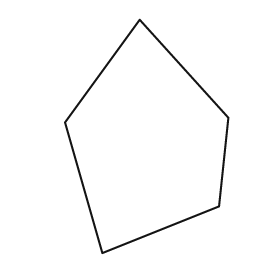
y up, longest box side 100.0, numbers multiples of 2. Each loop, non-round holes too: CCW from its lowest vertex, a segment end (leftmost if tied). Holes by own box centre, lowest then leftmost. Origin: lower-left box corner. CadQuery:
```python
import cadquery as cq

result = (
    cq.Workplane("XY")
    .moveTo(16.0, 0.0)
    .lineTo(66.0, 20.0)
    .lineTo(70.0, 58.0)
    .lineTo(32.0, 100.0)
    .lineTo(0.0, 56.0)
    .close()
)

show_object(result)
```